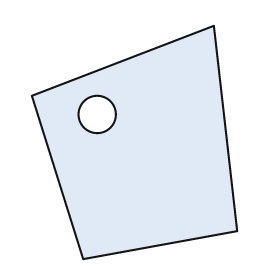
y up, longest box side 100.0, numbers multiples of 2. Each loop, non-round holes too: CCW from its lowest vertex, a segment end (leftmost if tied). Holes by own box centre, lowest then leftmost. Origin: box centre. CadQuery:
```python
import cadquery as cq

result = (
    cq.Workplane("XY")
    .moveTo(-22.0, -50.0)
    .lineTo(44.0, -38.0)
    .lineTo(34.0, 50.0)
    .lineTo(-44.0, 20.0)
    .close()
    .moveTo(-16.0, 12.0)
    .circle(8.0)
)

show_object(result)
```